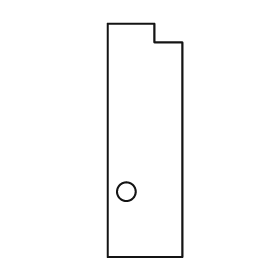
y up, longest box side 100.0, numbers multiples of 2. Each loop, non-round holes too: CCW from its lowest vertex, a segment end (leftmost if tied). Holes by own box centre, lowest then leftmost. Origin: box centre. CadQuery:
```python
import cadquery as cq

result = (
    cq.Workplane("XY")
    .moveTo(-16.0, -50.0)
    .lineTo(16.0, -50.0)
    .lineTo(16.0, 42.0)
    .lineTo(4.0, 42.0)
    .lineTo(4.0, 50.0)
    .lineTo(-16.0, 50.0)
    .close()
    .moveTo(-8.0, -22.0)
    .circle(4.0)
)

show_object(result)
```